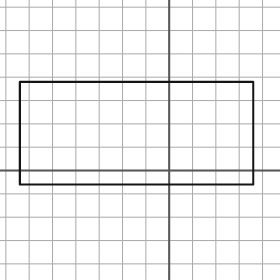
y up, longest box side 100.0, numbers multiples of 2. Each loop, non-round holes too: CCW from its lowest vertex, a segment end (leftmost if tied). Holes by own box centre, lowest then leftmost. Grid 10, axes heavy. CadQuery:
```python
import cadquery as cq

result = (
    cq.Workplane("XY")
    .moveTo(-64.0, -6.0)
    .lineTo(36.0, -6.0)
    .lineTo(36.0, 38.0)
    .lineTo(-64.0, 38.0)
    .close()
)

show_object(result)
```